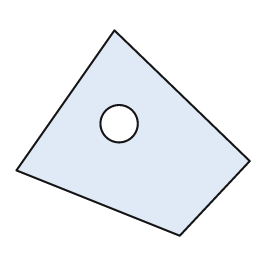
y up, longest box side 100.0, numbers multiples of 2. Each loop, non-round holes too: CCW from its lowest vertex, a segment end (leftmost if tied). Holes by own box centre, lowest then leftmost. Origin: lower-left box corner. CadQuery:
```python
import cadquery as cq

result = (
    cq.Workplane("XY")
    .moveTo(70.0, 0.0)
    .lineTo(100.0, 32.0)
    .lineTo(42.0, 88.0)
    .lineTo(0.0, 28.0)
    .close()
    .moveTo(44.0, 48.0)
    .circle(8.0)
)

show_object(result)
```